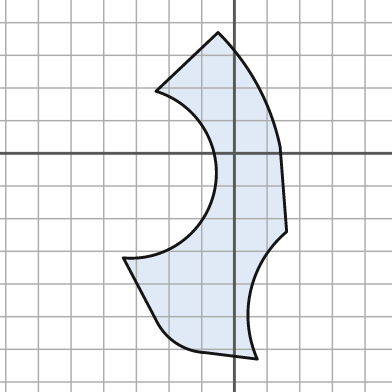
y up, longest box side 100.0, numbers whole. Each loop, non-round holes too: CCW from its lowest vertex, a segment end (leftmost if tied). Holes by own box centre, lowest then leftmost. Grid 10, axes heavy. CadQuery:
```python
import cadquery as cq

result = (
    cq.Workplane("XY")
    .moveTo(7.0, -63.0)
    .threePointArc((5.0, -42.0), (16.0, -24.0))
    .lineTo(14.0, 2.0)
    .threePointArc((7.0, 21.0), (-5.0, 37.0))
    .lineTo(-24.0, 19.0)
    .threePointArc((-6.0, -11.0), (-34.0, -32.0))
    .lineTo(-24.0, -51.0)
    .threePointArc((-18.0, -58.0), (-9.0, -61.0))
    .close()
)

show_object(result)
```